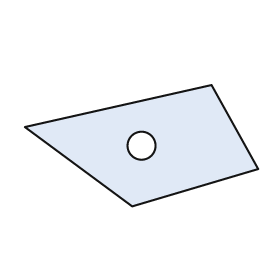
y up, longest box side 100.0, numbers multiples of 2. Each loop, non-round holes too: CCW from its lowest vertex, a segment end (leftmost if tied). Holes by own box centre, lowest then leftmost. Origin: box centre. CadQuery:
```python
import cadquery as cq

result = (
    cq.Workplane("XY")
    .moveTo(-4.0, -26.0)
    .lineTo(50.0, -10.0)
    .lineTo(30.0, 26.0)
    .lineTo(-50.0, 8.0)
    .close()
    .moveTo(0.0, 0.0)
    .circle(6.0)
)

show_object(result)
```